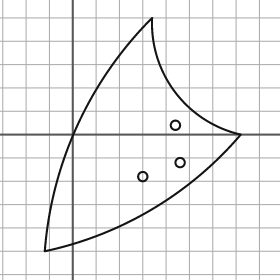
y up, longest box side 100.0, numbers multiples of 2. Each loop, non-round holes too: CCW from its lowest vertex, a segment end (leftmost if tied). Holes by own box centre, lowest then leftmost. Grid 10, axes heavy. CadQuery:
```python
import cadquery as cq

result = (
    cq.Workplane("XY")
    .moveTo(-12.0, -50.0)
    .threePointArc((34.0, -32.0), (72.0, 0.0))
    .threePointArc((44.0, 18.0), (34.0, 50.0))
    .threePointArc((2.0, 4.0), (-12.0, -50.0))
    .close()
    .moveTo(30.0, -18.0)
    .circle(2.0)
    .moveTo(46.0, -12.0)
    .circle(2.0)
    .moveTo(44.0, 4.0)
    .circle(2.0)
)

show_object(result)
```